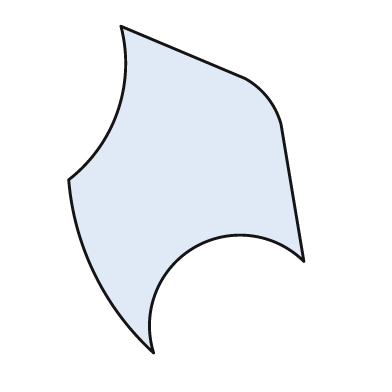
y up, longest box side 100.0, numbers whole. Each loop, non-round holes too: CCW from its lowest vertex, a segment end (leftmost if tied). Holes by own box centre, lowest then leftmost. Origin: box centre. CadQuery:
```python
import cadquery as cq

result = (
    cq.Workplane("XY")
    .moveTo(-10.0, -50.0)
    .threePointArc((2.0, -18.0), (36.0, -22.0))
    .lineTo(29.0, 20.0)
    .threePointArc((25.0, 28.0), (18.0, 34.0))
    .lineTo(-20.0, 50.0)
    .threePointArc((-21.0, 24.0), (-36.0, 3.0))
    .threePointArc((-28.0, -26.0), (-10.0, -50.0))
    .close()
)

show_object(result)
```